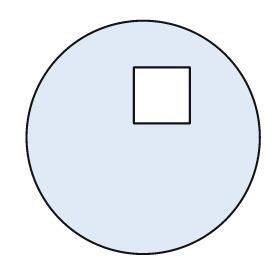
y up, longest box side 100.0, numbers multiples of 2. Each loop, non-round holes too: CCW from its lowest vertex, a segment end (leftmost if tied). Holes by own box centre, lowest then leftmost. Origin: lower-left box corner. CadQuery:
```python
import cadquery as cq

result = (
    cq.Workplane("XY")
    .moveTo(50.0, 50.0)
    .circle(50.0)
    .moveTo(46.0, 56.0)
    .lineTo(70.0, 56.0)
    .lineTo(70.0, 80.0)
    .lineTo(46.0, 80.0)
    .close()
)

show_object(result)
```